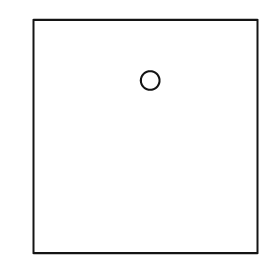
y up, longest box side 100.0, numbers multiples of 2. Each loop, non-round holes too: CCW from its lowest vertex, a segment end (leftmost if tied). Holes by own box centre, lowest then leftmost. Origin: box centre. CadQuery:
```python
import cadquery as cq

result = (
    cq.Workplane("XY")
    .moveTo(-48.0, -50.0)
    .lineTo(48.0, -50.0)
    .lineTo(48.0, 50.0)
    .lineTo(-48.0, 50.0)
    .close()
    .moveTo(2.0, 24.0)
    .circle(4.0)
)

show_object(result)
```